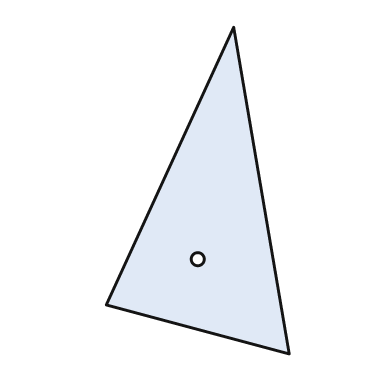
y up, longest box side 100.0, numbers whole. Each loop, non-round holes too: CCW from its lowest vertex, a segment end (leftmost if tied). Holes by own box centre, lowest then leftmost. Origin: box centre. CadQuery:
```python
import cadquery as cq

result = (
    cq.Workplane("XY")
    .moveTo(28.0, -50.0)
    .lineTo(11.0, 50.0)
    .lineTo(-28.0, -35.0)
    .close()
    .moveTo(0.0, -21.0)
    .circle(2.0)
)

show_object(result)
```